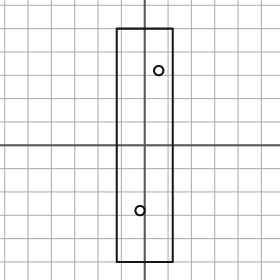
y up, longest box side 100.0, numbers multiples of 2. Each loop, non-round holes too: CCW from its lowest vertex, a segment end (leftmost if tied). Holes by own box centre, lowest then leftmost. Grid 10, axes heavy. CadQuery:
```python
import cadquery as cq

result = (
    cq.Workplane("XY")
    .moveTo(-12.0, -50.0)
    .lineTo(12.0, -50.0)
    .lineTo(12.0, 50.0)
    .lineTo(-12.0, 50.0)
    .close()
    .moveTo(-2.0, -28.0)
    .circle(2.0)
    .moveTo(6.0, 32.0)
    .circle(2.0)
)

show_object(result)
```